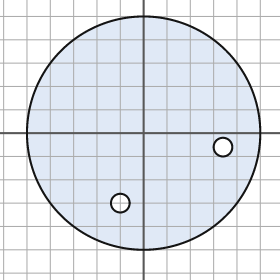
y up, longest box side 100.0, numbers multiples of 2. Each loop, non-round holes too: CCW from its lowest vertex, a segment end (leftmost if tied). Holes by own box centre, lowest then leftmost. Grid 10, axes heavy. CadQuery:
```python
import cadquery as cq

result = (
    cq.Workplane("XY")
    .moveTo(0.0, 0.0)
    .circle(50.0)
    .moveTo(-10.0, -30.0)
    .circle(4.0)
    .moveTo(34.0, -6.0)
    .circle(4.0)
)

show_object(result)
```